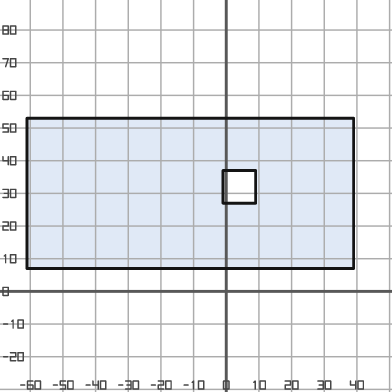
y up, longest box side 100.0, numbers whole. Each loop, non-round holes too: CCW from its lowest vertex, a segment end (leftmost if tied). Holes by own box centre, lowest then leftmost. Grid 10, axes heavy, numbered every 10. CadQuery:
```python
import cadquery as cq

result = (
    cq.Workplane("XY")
    .moveTo(-61.0, 7.0)
    .lineTo(39.0, 7.0)
    .lineTo(39.0, 53.0)
    .lineTo(-61.0, 53.0)
    .close()
    .moveTo(-1.0, 27.0)
    .lineTo(9.0, 27.0)
    .lineTo(9.0, 37.0)
    .lineTo(-1.0, 37.0)
    .close()
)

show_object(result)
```